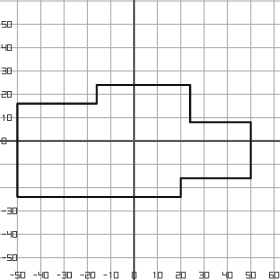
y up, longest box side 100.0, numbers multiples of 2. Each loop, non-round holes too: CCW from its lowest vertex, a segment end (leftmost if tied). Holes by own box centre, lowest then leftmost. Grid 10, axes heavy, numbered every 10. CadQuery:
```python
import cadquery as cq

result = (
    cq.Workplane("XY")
    .moveTo(-50.0, -24.0)
    .lineTo(20.0, -24.0)
    .lineTo(20.0, -16.0)
    .lineTo(50.0, -16.0)
    .lineTo(50.0, 8.0)
    .lineTo(24.0, 8.0)
    .lineTo(24.0, 24.0)
    .lineTo(-16.0, 24.0)
    .lineTo(-16.0, 16.0)
    .lineTo(-50.0, 16.0)
    .close()
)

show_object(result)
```